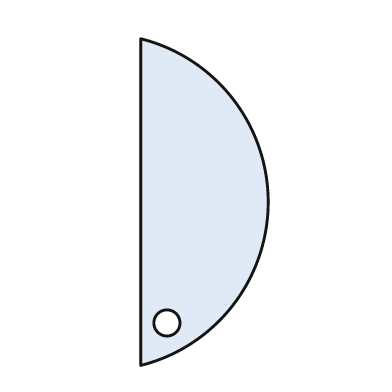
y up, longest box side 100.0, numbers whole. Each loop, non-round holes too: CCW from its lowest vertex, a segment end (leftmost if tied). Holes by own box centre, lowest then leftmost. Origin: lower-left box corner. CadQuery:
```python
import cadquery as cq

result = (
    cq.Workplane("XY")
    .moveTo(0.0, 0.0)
    .threePointArc((39.0, 50.0), (0.0, 100.0))
    .close()
    .moveTo(8.0, 13.0)
    .circle(4.0)
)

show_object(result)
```